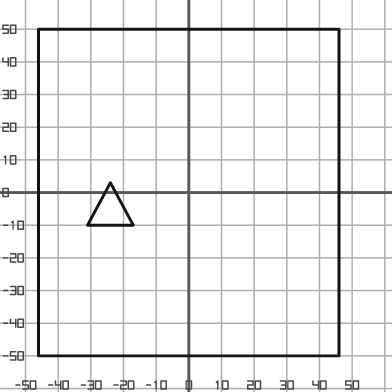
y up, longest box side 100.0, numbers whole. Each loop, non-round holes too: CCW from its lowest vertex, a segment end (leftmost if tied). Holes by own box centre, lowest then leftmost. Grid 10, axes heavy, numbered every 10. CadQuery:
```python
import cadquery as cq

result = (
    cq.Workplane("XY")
    .moveTo(-46.0, -50.0)
    .lineTo(46.0, -50.0)
    .lineTo(46.0, 50.0)
    .lineTo(-46.0, 50.0)
    .close()
    .moveTo(-31.0, -10.0)
    .lineTo(-17.0, -10.0)
    .lineTo(-24.0, 3.0)
    .close()
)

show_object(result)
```